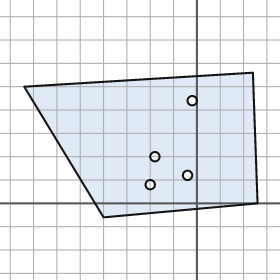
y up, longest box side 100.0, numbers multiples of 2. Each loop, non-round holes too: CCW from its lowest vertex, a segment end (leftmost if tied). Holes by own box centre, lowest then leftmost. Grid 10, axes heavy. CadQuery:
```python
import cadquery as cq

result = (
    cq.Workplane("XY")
    .moveTo(-40.0, -6.0)
    .lineTo(26.0, 0.0)
    .lineTo(24.0, 56.0)
    .lineTo(-74.0, 50.0)
    .close()
    .moveTo(-20.0, 8.0)
    .circle(2.0)
    .moveTo(-4.0, 12.0)
    .circle(2.0)
    .moveTo(-18.0, 20.0)
    .circle(2.0)
    .moveTo(-2.0, 44.0)
    .circle(2.0)
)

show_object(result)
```